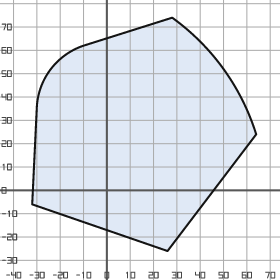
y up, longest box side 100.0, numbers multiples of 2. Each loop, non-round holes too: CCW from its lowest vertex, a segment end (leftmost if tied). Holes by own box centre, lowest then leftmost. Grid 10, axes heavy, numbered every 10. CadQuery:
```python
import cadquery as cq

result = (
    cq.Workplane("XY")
    .moveTo(26.0, -26.0)
    .lineTo(64.0, 24.0)
    .threePointArc((50.0, 52.0), (28.0, 74.0))
    .lineTo(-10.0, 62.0)
    .threePointArc((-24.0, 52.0), (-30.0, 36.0))
    .lineTo(-32.0, -6.0)
    .close()
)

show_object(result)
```